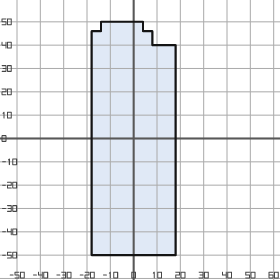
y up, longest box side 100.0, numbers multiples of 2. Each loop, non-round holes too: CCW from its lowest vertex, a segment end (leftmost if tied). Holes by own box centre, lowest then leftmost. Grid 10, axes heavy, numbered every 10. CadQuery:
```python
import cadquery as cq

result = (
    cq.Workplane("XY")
    .moveTo(-18.0, -50.0)
    .lineTo(18.0, -50.0)
    .lineTo(18.0, 40.0)
    .lineTo(8.0, 40.0)
    .lineTo(8.0, 46.0)
    .lineTo(4.0, 46.0)
    .lineTo(4.0, 50.0)
    .lineTo(-14.0, 50.0)
    .lineTo(-14.0, 46.0)
    .lineTo(-18.0, 46.0)
    .close()
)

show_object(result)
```